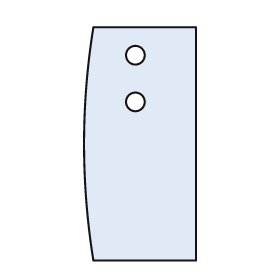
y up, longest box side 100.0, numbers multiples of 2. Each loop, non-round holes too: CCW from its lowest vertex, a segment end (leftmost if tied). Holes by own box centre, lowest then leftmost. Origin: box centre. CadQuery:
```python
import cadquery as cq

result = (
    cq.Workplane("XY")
    .moveTo(-20.0, -50.0)
    .lineTo(24.0, -50.0)
    .lineTo(24.0, 50.0)
    .lineTo(-20.0, 50.0)
    .threePointArc((-24.0, 0.0), (-20.0, -50.0))
    .close()
    .moveTo(-2.0, 18.0)
    .circle(4.0)
    .moveTo(-2.0, 38.0)
    .circle(4.0)
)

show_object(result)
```